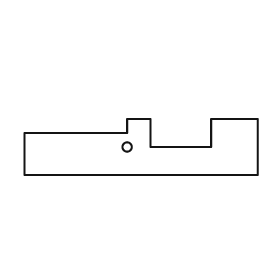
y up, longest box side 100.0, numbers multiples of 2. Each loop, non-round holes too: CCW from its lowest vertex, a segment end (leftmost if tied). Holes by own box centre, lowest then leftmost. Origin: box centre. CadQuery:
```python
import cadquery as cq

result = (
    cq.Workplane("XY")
    .moveTo(-50.0, -12.0)
    .lineTo(50.0, -12.0)
    .lineTo(50.0, 12.0)
    .lineTo(30.0, 12.0)
    .lineTo(30.0, 0.0)
    .lineTo(4.0, 0.0)
    .lineTo(4.0, 12.0)
    .lineTo(-6.0, 12.0)
    .lineTo(-6.0, 6.0)
    .lineTo(-50.0, 6.0)
    .close()
    .moveTo(-6.0, 0.0)
    .circle(2.0)
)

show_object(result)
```